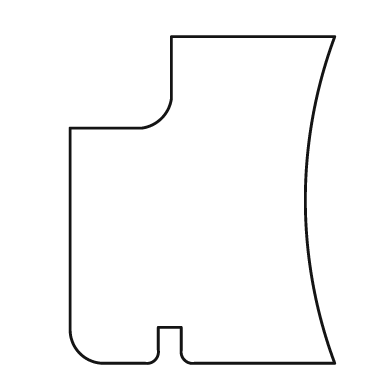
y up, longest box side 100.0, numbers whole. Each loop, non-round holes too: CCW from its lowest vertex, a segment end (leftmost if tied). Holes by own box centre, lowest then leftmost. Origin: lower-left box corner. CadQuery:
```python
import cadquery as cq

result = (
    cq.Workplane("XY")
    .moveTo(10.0, 0.0)
    .lineTo(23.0, 0.0)
    .threePointArc((26.0, 1.0), (27.0, 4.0))
    .lineTo(27.0, 11.0)
    .lineTo(34.0, 11.0)
    .lineTo(34.0, 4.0)
    .threePointArc((35.0, 1.0), (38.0, 0.0))
    .lineTo(81.0, 0.0)
    .threePointArc((72.0, 50.0), (81.0, 100.0))
    .lineTo(31.0, 100.0)
    .lineTo(31.0, 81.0)
    .threePointArc((28.0, 75.0), (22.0, 72.0))
    .lineTo(0.0, 72.0)
    .lineTo(0.0, 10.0)
    .threePointArc((3.0, 3.0), (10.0, 0.0))
    .close()
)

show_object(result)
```